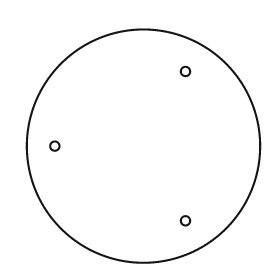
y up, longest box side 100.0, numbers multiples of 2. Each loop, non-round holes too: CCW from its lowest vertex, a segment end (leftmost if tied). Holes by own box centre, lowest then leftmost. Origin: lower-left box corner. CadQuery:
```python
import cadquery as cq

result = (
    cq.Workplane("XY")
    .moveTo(50.0, 50.0)
    .circle(50.0)
    .moveTo(68.0, 18.0)
    .circle(2.0)
    .moveTo(12.0, 50.0)
    .circle(2.0)
    .moveTo(68.0, 82.0)
    .circle(2.0)
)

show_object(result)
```